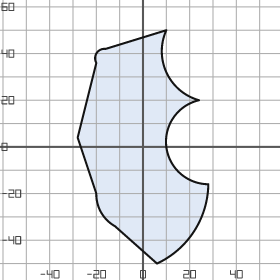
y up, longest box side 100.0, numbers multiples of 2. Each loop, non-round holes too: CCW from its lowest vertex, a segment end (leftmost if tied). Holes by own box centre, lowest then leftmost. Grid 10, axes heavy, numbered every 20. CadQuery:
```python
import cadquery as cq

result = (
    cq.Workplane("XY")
    .moveTo(6.0, -50.0)
    .threePointArc((22.0, -36.0), (28.0, -16.0))
    .threePointArc((10.0, 0.0), (24.0, 20.0))
    .threePointArc((10.0, 32.0), (10.0, 50.0))
    .lineTo(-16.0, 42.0)
    .threePointArc((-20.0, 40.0), (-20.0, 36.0))
    .lineTo(-28.0, 4.0)
    .lineTo(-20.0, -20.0)
    .threePointArc((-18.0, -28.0), (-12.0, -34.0))
    .close()
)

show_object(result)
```